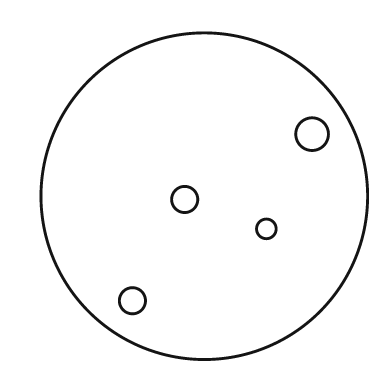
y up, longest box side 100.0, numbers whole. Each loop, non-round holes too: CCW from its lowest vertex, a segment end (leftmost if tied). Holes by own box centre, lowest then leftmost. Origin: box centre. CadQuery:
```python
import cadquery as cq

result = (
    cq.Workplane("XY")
    .moveTo(0.0, 0.0)
    .circle(50.0)
    .moveTo(-22.0, -32.0)
    .circle(4.0)
    .moveTo(19.0, -10.0)
    .circle(3.0)
    .moveTo(-6.0, -1.0)
    .circle(4.0)
    .moveTo(33.0, 19.0)
    .circle(5.0)
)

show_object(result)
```